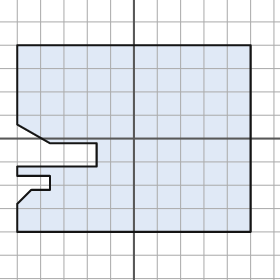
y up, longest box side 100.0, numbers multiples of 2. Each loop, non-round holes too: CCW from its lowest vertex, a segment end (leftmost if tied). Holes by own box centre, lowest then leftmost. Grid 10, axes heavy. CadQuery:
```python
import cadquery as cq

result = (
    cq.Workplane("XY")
    .moveTo(-50.0, -40.0)
    .lineTo(50.0, -40.0)
    .lineTo(50.0, 40.0)
    .lineTo(-50.0, 40.0)
    .lineTo(-50.0, 6.0)
    .lineTo(-36.0, -2.0)
    .lineTo(-16.0, -2.0)
    .lineTo(-16.0, -12.0)
    .lineTo(-50.0, -12.0)
    .lineTo(-50.0, -16.0)
    .lineTo(-36.0, -16.0)
    .lineTo(-36.0, -22.0)
    .lineTo(-44.0, -22.0)
    .lineTo(-50.0, -28.0)
    .close()
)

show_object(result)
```